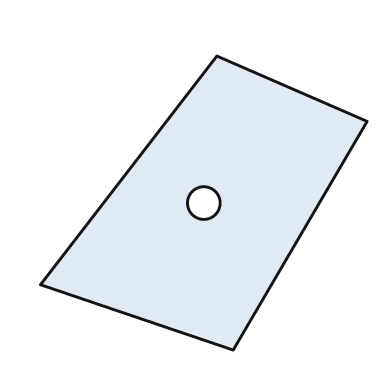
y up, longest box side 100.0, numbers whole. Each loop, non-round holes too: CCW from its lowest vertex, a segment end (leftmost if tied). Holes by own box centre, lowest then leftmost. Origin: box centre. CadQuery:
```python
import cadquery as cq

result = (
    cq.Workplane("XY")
    .moveTo(9.0, -45.0)
    .lineTo(50.0, 25.0)
    .lineTo(4.0, 45.0)
    .lineTo(-50.0, -25.0)
    .close()
    .moveTo(0.0, 0.0)
    .circle(5.0)
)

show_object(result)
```